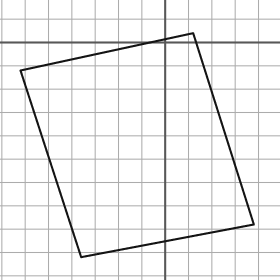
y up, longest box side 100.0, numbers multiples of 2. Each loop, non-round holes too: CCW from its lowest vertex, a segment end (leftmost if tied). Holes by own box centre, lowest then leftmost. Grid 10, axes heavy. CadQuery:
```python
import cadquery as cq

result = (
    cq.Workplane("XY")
    .moveTo(-36.0, -92.0)
    .lineTo(38.0, -78.0)
    .lineTo(12.0, 4.0)
    .lineTo(-62.0, -12.0)
    .close()
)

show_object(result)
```